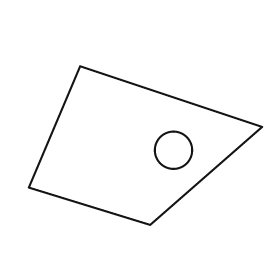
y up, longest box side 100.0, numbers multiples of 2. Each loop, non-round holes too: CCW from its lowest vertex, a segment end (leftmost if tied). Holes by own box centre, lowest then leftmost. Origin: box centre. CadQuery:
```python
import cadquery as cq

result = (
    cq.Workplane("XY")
    .moveTo(2.0, -34.0)
    .lineTo(50.0, 8.0)
    .lineTo(-28.0, 34.0)
    .lineTo(-50.0, -18.0)
    .close()
    .moveTo(12.0, -2.0)
    .circle(8.0)
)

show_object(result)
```